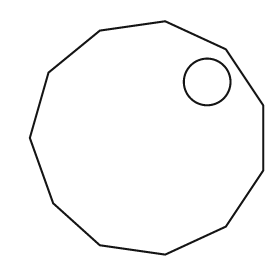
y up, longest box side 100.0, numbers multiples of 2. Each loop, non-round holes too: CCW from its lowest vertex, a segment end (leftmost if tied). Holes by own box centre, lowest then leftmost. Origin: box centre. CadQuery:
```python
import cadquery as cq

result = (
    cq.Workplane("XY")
    .moveTo(8.0, -50.0)
    .lineTo(34.0, -38.0)
    .lineTo(50.0, -14.0)
    .lineTo(50.0, 14.0)
    .lineTo(34.0, 38.0)
    .lineTo(8.0, 50.0)
    .lineTo(-20.0, 46.0)
    .lineTo(-42.0, 28.0)
    .lineTo(-50.0, 0.0)
    .lineTo(-40.0, -28.0)
    .lineTo(-20.0, -46.0)
    .close()
    .moveTo(26.0, 24.0)
    .circle(10.0)
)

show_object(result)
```